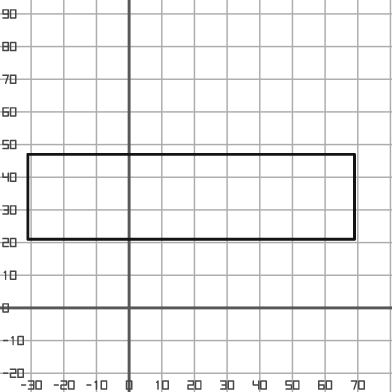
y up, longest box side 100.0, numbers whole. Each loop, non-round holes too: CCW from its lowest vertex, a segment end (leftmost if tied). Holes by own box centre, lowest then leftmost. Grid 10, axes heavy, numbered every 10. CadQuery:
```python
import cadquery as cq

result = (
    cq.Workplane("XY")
    .moveTo(-31.0, 21.0)
    .lineTo(69.0, 21.0)
    .lineTo(69.0, 47.0)
    .lineTo(-31.0, 47.0)
    .close()
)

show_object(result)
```